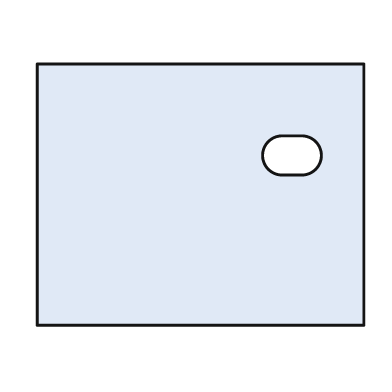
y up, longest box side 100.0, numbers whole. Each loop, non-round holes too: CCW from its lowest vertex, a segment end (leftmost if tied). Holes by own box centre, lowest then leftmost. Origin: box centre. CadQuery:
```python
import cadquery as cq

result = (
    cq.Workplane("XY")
    .moveTo(-50.0, -40.0)
    .lineTo(50.0, -40.0)
    .lineTo(50.0, 40.0)
    .lineTo(-50.0, 40.0)
    .close()
    .moveTo(25.0, 6.0)
    .lineTo(31.0, 6.0)
    .threePointArc((37.0, 12.0), (31.0, 18.0))
    .lineTo(25.0, 18.0)
    .threePointArc((19.0, 12.0), (25.0, 6.0))
    .close()
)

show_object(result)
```